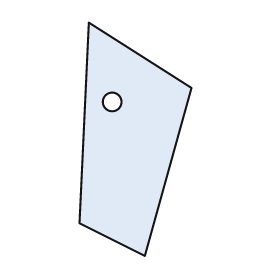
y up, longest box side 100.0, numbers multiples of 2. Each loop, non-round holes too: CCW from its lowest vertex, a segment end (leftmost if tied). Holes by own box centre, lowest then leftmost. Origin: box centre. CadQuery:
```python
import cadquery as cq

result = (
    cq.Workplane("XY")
    .moveTo(4.0, -50.0)
    .lineTo(24.0, 22.0)
    .lineTo(-20.0, 50.0)
    .lineTo(-24.0, -36.0)
    .close()
    .moveTo(-10.0, 16.0)
    .circle(4.0)
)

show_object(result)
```